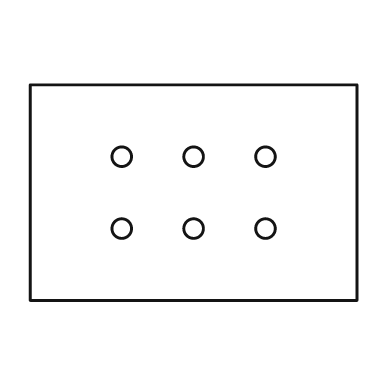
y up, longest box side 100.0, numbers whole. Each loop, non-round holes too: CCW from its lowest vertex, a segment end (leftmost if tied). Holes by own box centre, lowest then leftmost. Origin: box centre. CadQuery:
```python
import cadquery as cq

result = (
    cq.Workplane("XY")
    .moveTo(-50.0, -33.0)
    .lineTo(50.0, -33.0)
    .lineTo(50.0, 33.0)
    .lineTo(-50.0, 33.0)
    .close()
    .moveTo(-22.0, -11.0)
    .circle(3.0)
    .moveTo(0.0, -11.0)
    .circle(3.0)
    .moveTo(22.0, -11.0)
    .circle(3.0)
    .moveTo(-22.0, 11.0)
    .circle(3.0)
    .moveTo(0.0, 11.0)
    .circle(3.0)
    .moveTo(22.0, 11.0)
    .circle(3.0)
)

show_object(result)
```